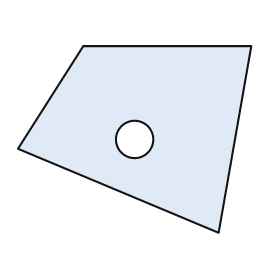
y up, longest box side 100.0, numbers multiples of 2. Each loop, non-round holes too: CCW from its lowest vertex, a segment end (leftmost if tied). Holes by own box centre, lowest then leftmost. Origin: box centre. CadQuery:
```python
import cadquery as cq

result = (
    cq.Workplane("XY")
    .moveTo(36.0, -40.0)
    .lineTo(50.0, 40.0)
    .lineTo(-22.0, 40.0)
    .lineTo(-50.0, -4.0)
    .close()
    .moveTo(0.0, 0.0)
    .circle(8.0)
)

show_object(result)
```